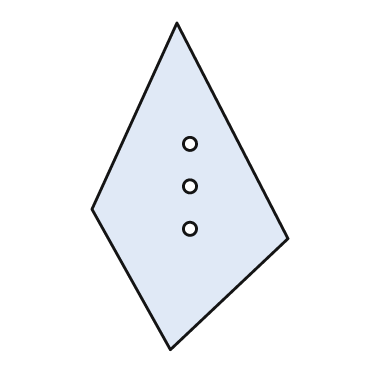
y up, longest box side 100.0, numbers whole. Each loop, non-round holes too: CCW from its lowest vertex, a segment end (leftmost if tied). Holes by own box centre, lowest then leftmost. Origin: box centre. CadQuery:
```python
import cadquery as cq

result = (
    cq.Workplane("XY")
    .moveTo(-6.0, -50.0)
    .lineTo(30.0, -16.0)
    .lineTo(-4.0, 50.0)
    .lineTo(-30.0, -7.0)
    .close()
    .moveTo(0.0, -13.0)
    .circle(2.0)
    .moveTo(0.0, 0.0)
    .circle(2.0)
    .moveTo(0.0, 13.0)
    .circle(2.0)
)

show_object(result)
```